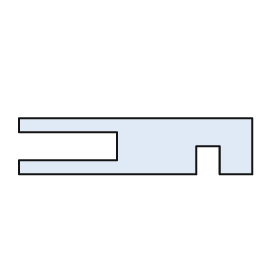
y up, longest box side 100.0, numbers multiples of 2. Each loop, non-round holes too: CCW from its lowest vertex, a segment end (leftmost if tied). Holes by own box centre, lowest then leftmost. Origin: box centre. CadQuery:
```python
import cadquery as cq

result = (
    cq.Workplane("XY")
    .moveTo(-50.0, -12.0)
    .lineTo(26.0, -12.0)
    .lineTo(26.0, 0.0)
    .lineTo(36.0, 0.0)
    .lineTo(36.0, -12.0)
    .lineTo(50.0, -12.0)
    .lineTo(50.0, 12.0)
    .lineTo(-50.0, 12.0)
    .lineTo(-50.0, 6.0)
    .lineTo(-8.0, 6.0)
    .lineTo(-8.0, -6.0)
    .lineTo(-50.0, -6.0)
    .close()
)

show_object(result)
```